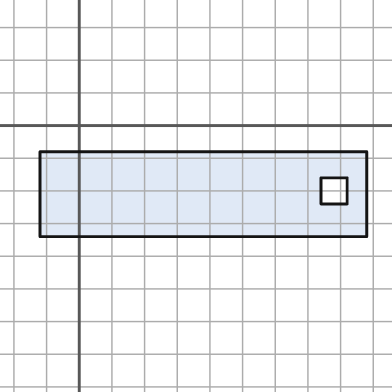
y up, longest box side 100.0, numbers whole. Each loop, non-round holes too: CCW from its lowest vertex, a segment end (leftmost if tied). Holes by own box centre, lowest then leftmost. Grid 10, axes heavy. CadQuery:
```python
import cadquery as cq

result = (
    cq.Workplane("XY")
    .moveTo(-12.0, -34.0)
    .lineTo(88.0, -34.0)
    .lineTo(88.0, -8.0)
    .lineTo(-12.0, -8.0)
    .close()
    .moveTo(74.0, -24.0)
    .lineTo(82.0, -24.0)
    .lineTo(82.0, -16.0)
    .lineTo(74.0, -16.0)
    .close()
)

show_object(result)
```